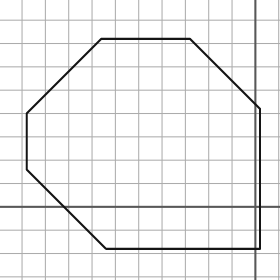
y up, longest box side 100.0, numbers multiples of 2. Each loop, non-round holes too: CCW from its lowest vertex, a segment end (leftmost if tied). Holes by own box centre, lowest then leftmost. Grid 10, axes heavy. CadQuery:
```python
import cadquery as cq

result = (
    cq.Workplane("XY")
    .moveTo(-64.0, -18.0)
    .lineTo(2.0, -18.0)
    .lineTo(2.0, 42.0)
    .lineTo(-28.0, 72.0)
    .lineTo(-66.0, 72.0)
    .lineTo(-98.0, 40.0)
    .lineTo(-98.0, 16.0)
    .close()
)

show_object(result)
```